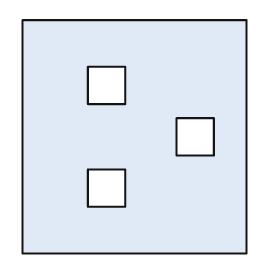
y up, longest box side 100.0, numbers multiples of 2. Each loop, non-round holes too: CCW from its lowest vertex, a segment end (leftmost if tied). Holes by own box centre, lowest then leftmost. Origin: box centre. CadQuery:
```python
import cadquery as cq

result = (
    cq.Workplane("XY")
    .moveTo(-48.0, -50.0)
    .lineTo(48.0, -50.0)
    .lineTo(48.0, 50.0)
    .lineTo(-48.0, 50.0)
    .close()
    .moveTo(-20.0, -30.0)
    .lineTo(-4.0, -30.0)
    .lineTo(-4.0, -14.0)
    .lineTo(-20.0, -14.0)
    .close()
    .moveTo(18.0, -8.0)
    .lineTo(34.0, -8.0)
    .lineTo(34.0, 8.0)
    .lineTo(18.0, 8.0)
    .close()
    .moveTo(-20.0, 14.0)
    .lineTo(-4.0, 14.0)
    .lineTo(-4.0, 30.0)
    .lineTo(-20.0, 30.0)
    .close()
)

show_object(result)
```